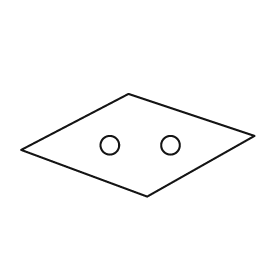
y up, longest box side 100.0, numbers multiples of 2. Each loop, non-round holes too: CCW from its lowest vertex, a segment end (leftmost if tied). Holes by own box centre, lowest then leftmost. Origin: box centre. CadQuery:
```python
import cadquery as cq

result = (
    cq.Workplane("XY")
    .moveTo(4.0, -22.0)
    .lineTo(50.0, 4.0)
    .lineTo(-4.0, 22.0)
    .lineTo(-50.0, -2.0)
    .close()
    .moveTo(-12.0, 0.0)
    .circle(4.0)
    .moveTo(14.0, 0.0)
    .circle(4.0)
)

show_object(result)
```